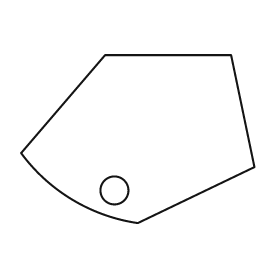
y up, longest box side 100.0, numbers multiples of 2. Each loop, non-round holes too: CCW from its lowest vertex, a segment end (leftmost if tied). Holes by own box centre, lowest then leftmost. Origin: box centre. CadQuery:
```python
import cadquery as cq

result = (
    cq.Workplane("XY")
    .moveTo(0.0, -36.0)
    .lineTo(50.0, -12.0)
    .lineTo(40.0, 36.0)
    .lineTo(-14.0, 36.0)
    .lineTo(-50.0, -6.0)
    .threePointArc((-28.0, -26.0), (0.0, -36.0))
    .close()
    .moveTo(-10.0, -22.0)
    .circle(6.0)
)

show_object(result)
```